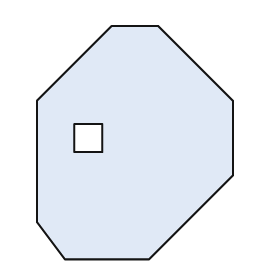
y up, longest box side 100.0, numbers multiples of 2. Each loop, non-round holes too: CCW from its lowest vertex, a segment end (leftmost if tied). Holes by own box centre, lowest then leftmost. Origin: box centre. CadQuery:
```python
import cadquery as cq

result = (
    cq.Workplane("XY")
    .moveTo(-30.0, -50.0)
    .lineTo(6.0, -50.0)
    .lineTo(42.0, -14.0)
    .lineTo(42.0, 18.0)
    .lineTo(10.0, 50.0)
    .lineTo(-10.0, 50.0)
    .lineTo(-42.0, 18.0)
    .lineTo(-42.0, -34.0)
    .close()
    .moveTo(-26.0, -4.0)
    .lineTo(-14.0, -4.0)
    .lineTo(-14.0, 8.0)
    .lineTo(-26.0, 8.0)
    .close()
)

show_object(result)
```